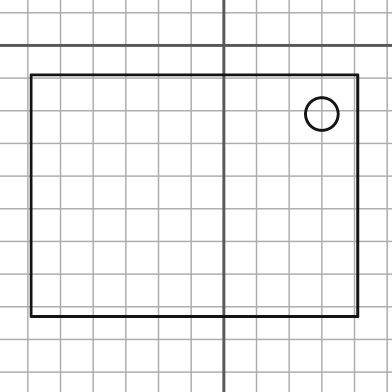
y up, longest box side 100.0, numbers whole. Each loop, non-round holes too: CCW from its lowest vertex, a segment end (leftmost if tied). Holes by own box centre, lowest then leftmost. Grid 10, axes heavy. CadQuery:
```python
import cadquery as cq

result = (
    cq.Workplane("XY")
    .moveTo(-59.0, -83.0)
    .lineTo(41.0, -83.0)
    .lineTo(41.0, -9.0)
    .lineTo(-59.0, -9.0)
    .close()
    .moveTo(30.0, -21.0)
    .circle(5.0)
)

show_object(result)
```